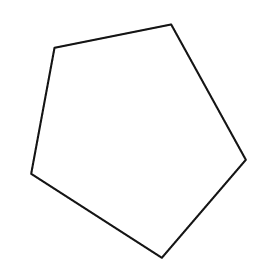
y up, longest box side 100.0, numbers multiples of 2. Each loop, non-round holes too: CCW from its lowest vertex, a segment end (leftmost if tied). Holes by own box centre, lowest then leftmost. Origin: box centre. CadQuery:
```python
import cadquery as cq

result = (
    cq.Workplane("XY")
    .moveTo(10.0, -50.0)
    .lineTo(46.0, -8.0)
    .lineTo(14.0, 50.0)
    .lineTo(-36.0, 40.0)
    .lineTo(-46.0, -14.0)
    .close()
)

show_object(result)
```